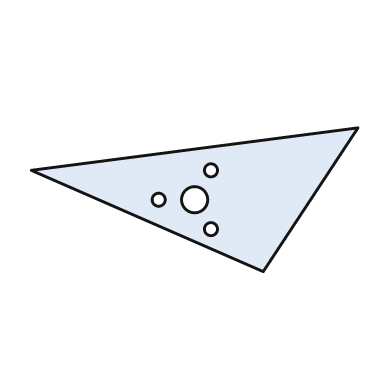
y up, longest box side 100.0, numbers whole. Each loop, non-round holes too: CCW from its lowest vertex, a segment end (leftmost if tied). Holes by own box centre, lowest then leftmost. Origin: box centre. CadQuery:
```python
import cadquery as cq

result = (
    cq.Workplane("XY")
    .moveTo(21.0, -22.0)
    .lineTo(50.0, 22.0)
    .lineTo(-50.0, 9.0)
    .close()
    .moveTo(5.0, -9.0)
    .circle(2.0)
    .moveTo(-11.0, 0.0)
    .circle(2.0)
    .moveTo(0.0, 0.0)
    .circle(4.0)
    .moveTo(5.0, 9.0)
    .circle(2.0)
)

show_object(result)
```